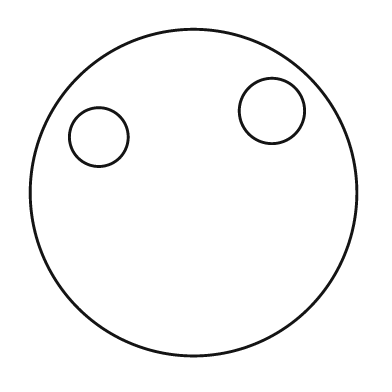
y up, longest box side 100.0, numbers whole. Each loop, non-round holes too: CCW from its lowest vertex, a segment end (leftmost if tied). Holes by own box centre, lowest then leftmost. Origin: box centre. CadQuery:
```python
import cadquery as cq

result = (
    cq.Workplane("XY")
    .moveTo(0.0, 0.0)
    .circle(50.0)
    .moveTo(-29.0, 17.0)
    .circle(9.0)
    .moveTo(24.0, 25.0)
    .circle(10.0)
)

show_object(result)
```